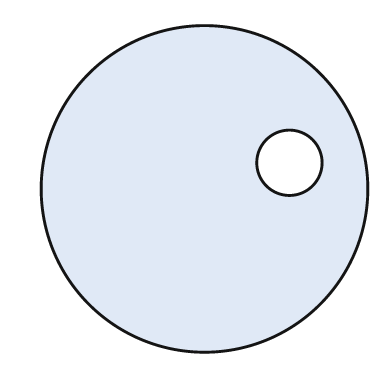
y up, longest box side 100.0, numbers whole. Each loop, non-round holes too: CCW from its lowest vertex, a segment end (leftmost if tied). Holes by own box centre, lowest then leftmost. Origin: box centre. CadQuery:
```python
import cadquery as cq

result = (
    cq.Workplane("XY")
    .moveTo(0.0, 0.0)
    .circle(50.0)
    .moveTo(26.0, 8.0)
    .circle(10.0)
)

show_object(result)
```